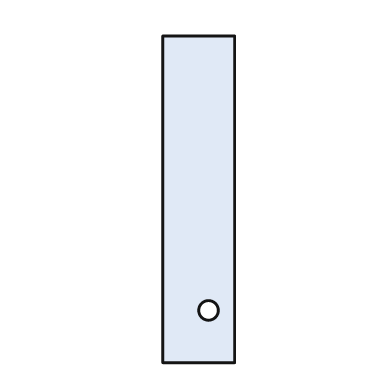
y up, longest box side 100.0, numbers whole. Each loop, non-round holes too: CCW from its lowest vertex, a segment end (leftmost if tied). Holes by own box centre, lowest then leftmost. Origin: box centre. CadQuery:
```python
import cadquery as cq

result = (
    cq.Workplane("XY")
    .moveTo(-11.0, -50.0)
    .lineTo(11.0, -50.0)
    .lineTo(11.0, 50.0)
    .lineTo(-11.0, 50.0)
    .close()
    .moveTo(3.0, -34.0)
    .circle(3.0)
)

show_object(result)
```